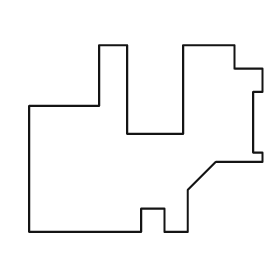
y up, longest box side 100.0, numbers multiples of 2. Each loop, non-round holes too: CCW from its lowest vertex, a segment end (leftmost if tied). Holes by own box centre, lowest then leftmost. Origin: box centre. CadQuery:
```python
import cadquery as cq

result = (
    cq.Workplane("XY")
    .moveTo(-50.0, -40.0)
    .lineTo(-2.0, -40.0)
    .lineTo(-2.0, -30.0)
    .lineTo(8.0, -30.0)
    .lineTo(8.0, -40.0)
    .lineTo(18.0, -40.0)
    .lineTo(18.0, -22.0)
    .lineTo(30.0, -10.0)
    .lineTo(50.0, -10.0)
    .lineTo(50.0, -6.0)
    .lineTo(46.0, -6.0)
    .lineTo(46.0, 20.0)
    .lineTo(50.0, 20.0)
    .lineTo(50.0, 30.0)
    .lineTo(38.0, 30.0)
    .lineTo(38.0, 40.0)
    .lineTo(16.0, 40.0)
    .lineTo(16.0, 2.0)
    .lineTo(-8.0, 2.0)
    .lineTo(-8.0, 40.0)
    .lineTo(-20.0, 40.0)
    .lineTo(-20.0, 14.0)
    .lineTo(-50.0, 14.0)
    .close()
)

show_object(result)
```